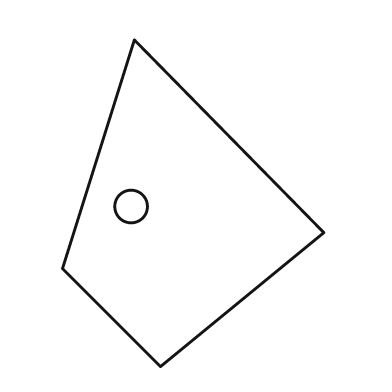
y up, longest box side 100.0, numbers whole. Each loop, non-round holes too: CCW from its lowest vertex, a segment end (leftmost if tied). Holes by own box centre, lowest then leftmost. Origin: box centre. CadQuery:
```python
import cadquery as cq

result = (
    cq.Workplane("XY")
    .moveTo(-10.0, -50.0)
    .lineTo(40.0, -9.0)
    .lineTo(-18.0, 50.0)
    .lineTo(-40.0, -20.0)
    .close()
    .moveTo(-19.0, -1.0)
    .circle(5.0)
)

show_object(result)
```